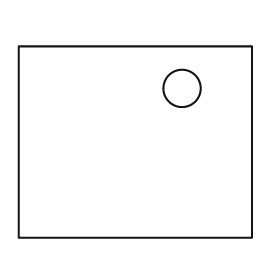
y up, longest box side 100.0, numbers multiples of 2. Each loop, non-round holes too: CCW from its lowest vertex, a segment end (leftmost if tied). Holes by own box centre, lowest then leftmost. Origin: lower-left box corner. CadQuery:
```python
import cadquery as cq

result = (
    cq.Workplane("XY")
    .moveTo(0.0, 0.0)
    .lineTo(100.0, 0.0)
    .lineTo(100.0, 82.0)
    .lineTo(0.0, 82.0)
    .close()
    .moveTo(70.0, 64.0)
    .circle(8.0)
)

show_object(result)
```